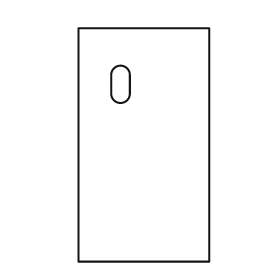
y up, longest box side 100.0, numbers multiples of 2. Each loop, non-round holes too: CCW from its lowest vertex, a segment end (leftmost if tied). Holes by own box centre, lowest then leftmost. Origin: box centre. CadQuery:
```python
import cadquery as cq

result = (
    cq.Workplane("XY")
    .moveTo(-28.0, -50.0)
    .lineTo(28.0, -50.0)
    .lineTo(28.0, 50.0)
    .lineTo(-28.0, 50.0)
    .close()
    .moveTo(-14.0, 22.0)
    .threePointArc((-10.0, 18.0), (-6.0, 22.0))
    .lineTo(-6.0, 30.0)
    .threePointArc((-10.0, 34.0), (-14.0, 30.0))
    .close()
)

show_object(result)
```